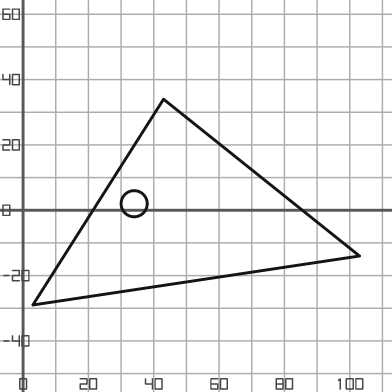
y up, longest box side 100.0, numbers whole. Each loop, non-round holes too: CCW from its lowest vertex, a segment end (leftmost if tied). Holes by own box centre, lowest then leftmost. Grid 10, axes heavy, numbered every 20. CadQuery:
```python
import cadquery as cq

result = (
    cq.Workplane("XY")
    .moveTo(3.0, -29.0)
    .lineTo(103.0, -14.0)
    .lineTo(43.0, 34.0)
    .close()
    .moveTo(34.0, 2.0)
    .circle(4.0)
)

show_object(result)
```